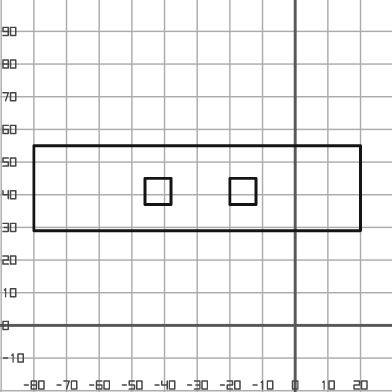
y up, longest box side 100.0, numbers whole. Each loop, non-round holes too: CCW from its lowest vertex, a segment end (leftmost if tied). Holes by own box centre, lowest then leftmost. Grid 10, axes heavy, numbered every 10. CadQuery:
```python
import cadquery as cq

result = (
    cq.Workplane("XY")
    .moveTo(-80.0, 29.0)
    .lineTo(20.0, 29.0)
    .lineTo(20.0, 55.0)
    .lineTo(-80.0, 55.0)
    .close()
    .moveTo(-46.0, 37.0)
    .lineTo(-38.0, 37.0)
    .lineTo(-38.0, 45.0)
    .lineTo(-46.0, 45.0)
    .close()
    .moveTo(-20.0, 37.0)
    .lineTo(-12.0, 37.0)
    .lineTo(-12.0, 45.0)
    .lineTo(-20.0, 45.0)
    .close()
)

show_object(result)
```